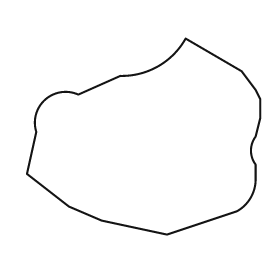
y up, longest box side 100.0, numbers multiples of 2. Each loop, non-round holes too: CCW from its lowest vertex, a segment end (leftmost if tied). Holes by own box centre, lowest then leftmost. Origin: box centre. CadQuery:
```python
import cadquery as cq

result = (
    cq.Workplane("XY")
    .moveTo(10.0, -42.0)
    .lineTo(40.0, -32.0)
    .threePointArc((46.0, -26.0), (48.0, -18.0))
    .lineTo(48.0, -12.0)
    .threePointArc((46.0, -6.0), (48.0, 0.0))
    .lineTo(50.0, 8.0)
    .lineTo(50.0, 16.0)
    .lineTo(48.0, 20.0)
    .lineTo(42.0, 28.0)
    .lineTo(18.0, 42.0)
    .threePointArc((6.0, 30.0), (-10.0, 26.0))
    .lineTo(-28.0, 18.0)
    .threePointArc((-42.0, 16.0), (-46.0, 2.0))
    .lineTo(-50.0, -16.0)
    .lineTo(-32.0, -30.0)
    .lineTo(-18.0, -36.0)
    .close()
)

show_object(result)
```